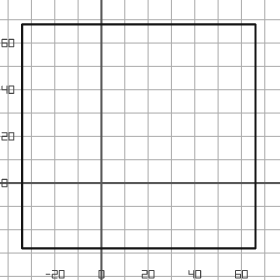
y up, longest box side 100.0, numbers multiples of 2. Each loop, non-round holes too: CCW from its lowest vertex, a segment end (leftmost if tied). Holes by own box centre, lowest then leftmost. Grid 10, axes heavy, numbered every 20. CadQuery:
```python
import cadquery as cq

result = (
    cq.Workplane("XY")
    .moveTo(-34.0, -28.0)
    .lineTo(66.0, -28.0)
    .lineTo(66.0, 68.0)
    .lineTo(-34.0, 68.0)
    .close()
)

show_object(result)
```